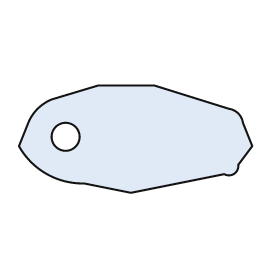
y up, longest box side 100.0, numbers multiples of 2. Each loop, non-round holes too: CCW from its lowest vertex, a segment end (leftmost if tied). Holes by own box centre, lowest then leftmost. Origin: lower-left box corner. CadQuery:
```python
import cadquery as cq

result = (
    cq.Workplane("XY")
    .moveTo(48.0, 0.0)
    .lineTo(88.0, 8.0)
    .threePointArc((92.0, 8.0), (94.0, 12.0))
    .lineTo(100.0, 20.0)
    .lineTo(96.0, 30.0)
    .threePointArc((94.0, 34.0), (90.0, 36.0))
    .lineTo(58.0, 46.0)
    .lineTo(34.0, 46.0)
    .lineTo(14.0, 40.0)
    .threePointArc((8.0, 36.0), (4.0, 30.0))
    .lineTo(0.0, 20.0)
    .threePointArc((12.0, 8.0), (28.0, 4.0))
    .close()
    .moveTo(20.0, 24.0)
    .circle(6.0)
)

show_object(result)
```